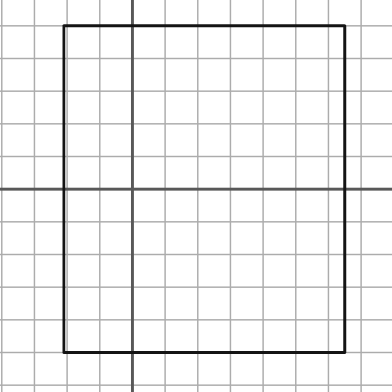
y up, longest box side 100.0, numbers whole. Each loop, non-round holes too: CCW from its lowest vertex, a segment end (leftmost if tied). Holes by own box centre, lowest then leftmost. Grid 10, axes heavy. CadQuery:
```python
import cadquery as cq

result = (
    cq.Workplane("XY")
    .moveTo(-21.0, -50.0)
    .lineTo(65.0, -50.0)
    .lineTo(65.0, 50.0)
    .lineTo(-21.0, 50.0)
    .close()
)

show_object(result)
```